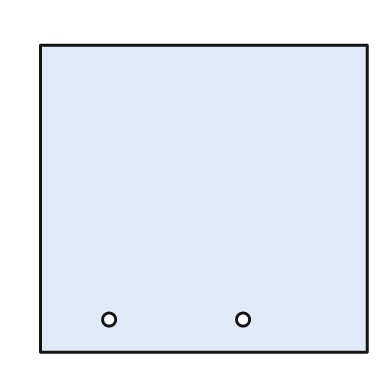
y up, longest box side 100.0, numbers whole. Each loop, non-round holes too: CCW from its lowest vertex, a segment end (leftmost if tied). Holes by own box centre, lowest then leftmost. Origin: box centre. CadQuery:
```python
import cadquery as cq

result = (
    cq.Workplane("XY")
    .moveTo(-50.0, -47.0)
    .lineTo(50.0, -47.0)
    .lineTo(50.0, 47.0)
    .lineTo(-50.0, 47.0)
    .close()
    .moveTo(-29.0, -37.0)
    .circle(2.0)
    .moveTo(12.0, -37.0)
    .circle(2.0)
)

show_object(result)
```